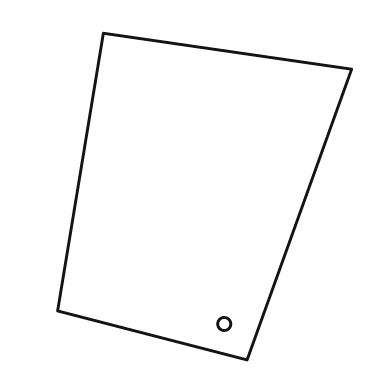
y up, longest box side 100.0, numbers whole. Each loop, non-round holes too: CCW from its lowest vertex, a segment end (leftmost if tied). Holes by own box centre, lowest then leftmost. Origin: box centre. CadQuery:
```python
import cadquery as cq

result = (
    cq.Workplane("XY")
    .moveTo(13.0, -50.0)
    .lineTo(45.0, 39.0)
    .lineTo(-31.0, 50.0)
    .lineTo(-45.0, -35.0)
    .close()
    .moveTo(6.0, -39.0)
    .circle(2.0)
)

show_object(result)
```